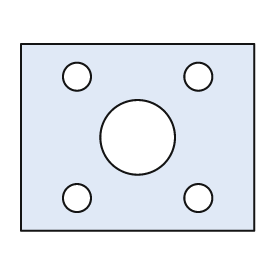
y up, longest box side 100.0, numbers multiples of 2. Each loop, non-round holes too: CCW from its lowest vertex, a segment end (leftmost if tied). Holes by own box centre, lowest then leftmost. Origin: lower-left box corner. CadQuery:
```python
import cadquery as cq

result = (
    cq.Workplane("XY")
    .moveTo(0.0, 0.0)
    .lineTo(100.0, 0.0)
    .lineTo(100.0, 80.0)
    .lineTo(0.0, 80.0)
    .close()
    .moveTo(24.0, 14.0)
    .circle(6.0)
    .moveTo(76.0, 14.0)
    .circle(6.0)
    .moveTo(50.0, 40.0)
    .circle(16.0)
    .moveTo(24.0, 66.0)
    .circle(6.0)
    .moveTo(76.0, 66.0)
    .circle(6.0)
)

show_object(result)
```